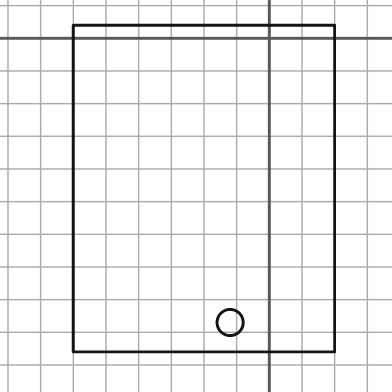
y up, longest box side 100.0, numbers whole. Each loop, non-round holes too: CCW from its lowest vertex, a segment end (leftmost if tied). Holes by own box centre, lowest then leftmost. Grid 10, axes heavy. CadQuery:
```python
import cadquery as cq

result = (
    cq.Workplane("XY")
    .moveTo(-60.0, -96.0)
    .lineTo(20.0, -96.0)
    .lineTo(20.0, 4.0)
    .lineTo(-60.0, 4.0)
    .close()
    .moveTo(-12.0, -87.0)
    .circle(4.0)
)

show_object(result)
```